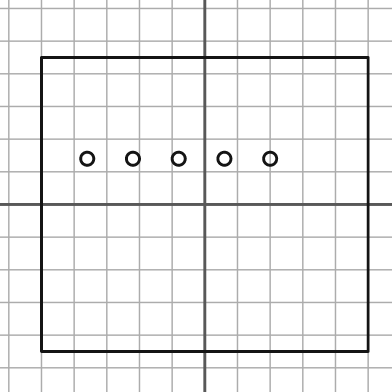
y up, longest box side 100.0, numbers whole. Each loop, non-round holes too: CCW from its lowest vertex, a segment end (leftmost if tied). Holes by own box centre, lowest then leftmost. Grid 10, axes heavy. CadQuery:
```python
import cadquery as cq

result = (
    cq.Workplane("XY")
    .moveTo(-50.0, -45.0)
    .lineTo(50.0, -45.0)
    .lineTo(50.0, 45.0)
    .lineTo(-50.0, 45.0)
    .close()
    .moveTo(-36.0, 14.0)
    .circle(2.0)
    .moveTo(-22.0, 14.0)
    .circle(2.0)
    .moveTo(-8.0, 14.0)
    .circle(2.0)
    .moveTo(6.0, 14.0)
    .circle(2.0)
    .moveTo(20.0, 14.0)
    .circle(2.0)
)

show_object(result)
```